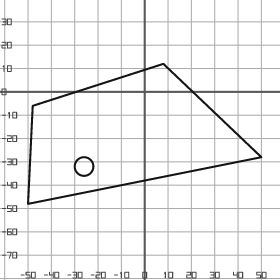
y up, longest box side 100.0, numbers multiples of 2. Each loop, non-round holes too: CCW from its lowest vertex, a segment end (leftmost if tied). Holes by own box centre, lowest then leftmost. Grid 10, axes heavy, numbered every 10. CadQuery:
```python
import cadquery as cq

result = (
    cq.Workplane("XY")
    .moveTo(-50.0, -48.0)
    .lineTo(50.0, -28.0)
    .lineTo(8.0, 12.0)
    .lineTo(-48.0, -6.0)
    .close()
    .moveTo(-26.0, -32.0)
    .circle(4.0)
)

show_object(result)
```